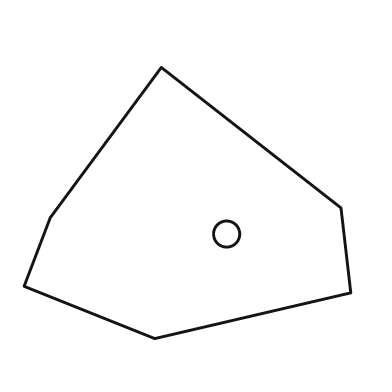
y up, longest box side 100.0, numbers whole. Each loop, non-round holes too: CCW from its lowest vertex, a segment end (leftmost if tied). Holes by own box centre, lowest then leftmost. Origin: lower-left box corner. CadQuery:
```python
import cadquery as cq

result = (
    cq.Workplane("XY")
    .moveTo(40.0, 0.0)
    .lineTo(100.0, 14.0)
    .lineTo(97.0, 40.0)
    .lineTo(42.0, 83.0)
    .lineTo(8.0, 37.0)
    .lineTo(0.0, 16.0)
    .close()
    .moveTo(62.0, 32.0)
    .circle(4.0)
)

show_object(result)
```